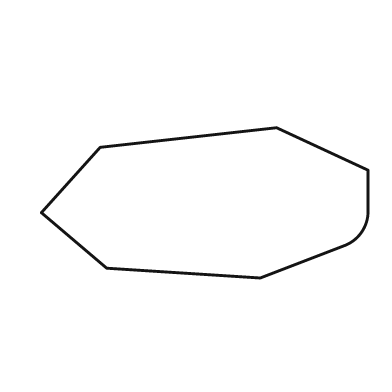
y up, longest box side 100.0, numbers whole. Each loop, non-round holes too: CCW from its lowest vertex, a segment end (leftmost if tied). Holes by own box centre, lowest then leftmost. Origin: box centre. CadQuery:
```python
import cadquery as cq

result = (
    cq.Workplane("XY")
    .moveTo(17.0, -23.0)
    .lineTo(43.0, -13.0)
    .threePointArc((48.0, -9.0), (50.0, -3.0))
    .lineTo(50.0, 10.0)
    .lineTo(22.0, 23.0)
    .lineTo(-32.0, 17.0)
    .lineTo(-50.0, -3.0)
    .lineTo(-30.0, -20.0)
    .close()
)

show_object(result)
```